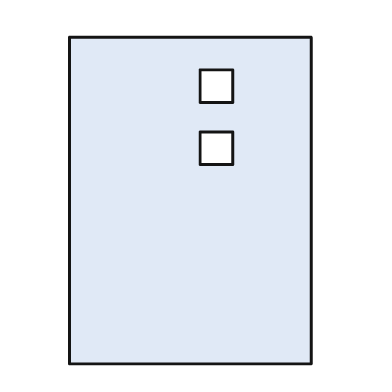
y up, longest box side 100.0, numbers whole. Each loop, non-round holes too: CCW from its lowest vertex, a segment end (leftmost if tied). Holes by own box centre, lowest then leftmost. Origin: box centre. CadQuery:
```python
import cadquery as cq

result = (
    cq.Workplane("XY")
    .moveTo(-37.0, -50.0)
    .lineTo(37.0, -50.0)
    .lineTo(37.0, 50.0)
    .lineTo(-37.0, 50.0)
    .close()
    .moveTo(3.0, 11.0)
    .lineTo(13.0, 11.0)
    .lineTo(13.0, 21.0)
    .lineTo(3.0, 21.0)
    .close()
    .moveTo(3.0, 30.0)
    .lineTo(13.0, 30.0)
    .lineTo(13.0, 40.0)
    .lineTo(3.0, 40.0)
    .close()
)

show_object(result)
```